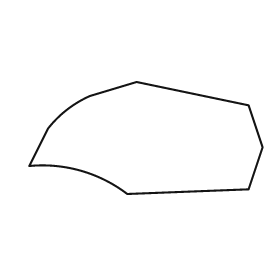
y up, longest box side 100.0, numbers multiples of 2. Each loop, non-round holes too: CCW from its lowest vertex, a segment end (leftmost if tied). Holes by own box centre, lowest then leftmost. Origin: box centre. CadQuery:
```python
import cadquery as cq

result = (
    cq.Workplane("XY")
    .moveTo(-8.0, -24.0)
    .lineTo(44.0, -22.0)
    .lineTo(50.0, -4.0)
    .lineTo(44.0, 14.0)
    .lineTo(-4.0, 24.0)
    .lineTo(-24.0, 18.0)
    .threePointArc((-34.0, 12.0), (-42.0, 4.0))
    .lineTo(-50.0, -12.0)
    .threePointArc((-28.0, -14.0), (-8.0, -24.0))
    .close()
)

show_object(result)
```